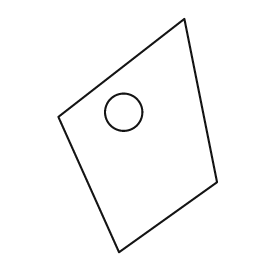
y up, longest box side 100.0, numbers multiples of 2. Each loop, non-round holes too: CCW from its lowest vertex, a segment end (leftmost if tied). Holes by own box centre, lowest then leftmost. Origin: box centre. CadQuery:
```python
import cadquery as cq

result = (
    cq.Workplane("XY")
    .moveTo(-8.0, -50.0)
    .lineTo(34.0, -20.0)
    .lineTo(20.0, 50.0)
    .lineTo(-34.0, 8.0)
    .close()
    .moveTo(-6.0, 10.0)
    .circle(8.0)
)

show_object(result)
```